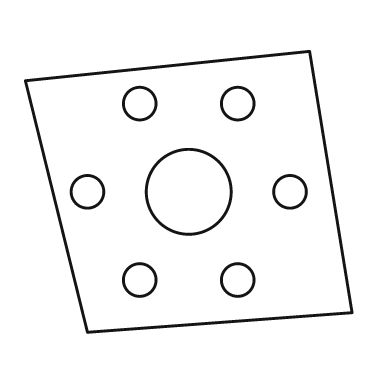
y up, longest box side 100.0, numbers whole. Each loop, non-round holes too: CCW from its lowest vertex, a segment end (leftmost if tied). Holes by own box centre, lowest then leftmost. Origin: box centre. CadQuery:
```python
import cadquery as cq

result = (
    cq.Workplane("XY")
    .moveTo(-31.0, -43.0)
    .lineTo(50.0, -37.0)
    .lineTo(37.0, 43.0)
    .lineTo(-50.0, 34.0)
    .close()
    .moveTo(-15.0, -27.0)
    .circle(5.0)
    .moveTo(15.0, -27.0)
    .circle(5.0)
    .moveTo(-31.0, 0.0)
    .circle(5.0)
    .moveTo(0.0, 0.0)
    .circle(13.0)
    .moveTo(31.0, 0.0)
    .circle(5.0)
    .moveTo(-15.0, 27.0)
    .circle(5.0)
    .moveTo(15.0, 27.0)
    .circle(5.0)
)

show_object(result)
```